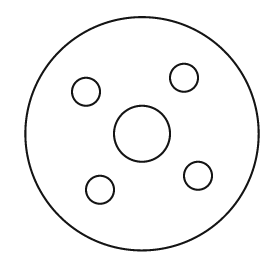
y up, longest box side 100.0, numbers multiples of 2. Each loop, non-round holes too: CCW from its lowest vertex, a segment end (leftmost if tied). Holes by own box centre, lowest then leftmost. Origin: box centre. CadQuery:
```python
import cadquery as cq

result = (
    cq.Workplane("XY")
    .moveTo(0.0, 0.0)
    .circle(50.0)
    .moveTo(-18.0, -24.0)
    .circle(6.0)
    .moveTo(24.0, -18.0)
    .circle(6.0)
    .moveTo(0.0, 0.0)
    .circle(12.0)
    .moveTo(-24.0, 18.0)
    .circle(6.0)
    .moveTo(18.0, 24.0)
    .circle(6.0)
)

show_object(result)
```